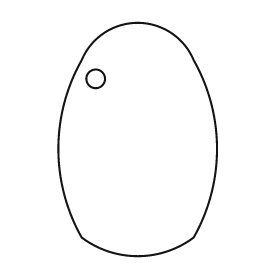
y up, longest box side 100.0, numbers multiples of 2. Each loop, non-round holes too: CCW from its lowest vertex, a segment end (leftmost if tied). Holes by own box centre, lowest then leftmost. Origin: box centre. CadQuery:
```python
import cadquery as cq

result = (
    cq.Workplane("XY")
    .moveTo(-24.0, -42.0)
    .threePointArc((0.0, -50.0), (24.0, -42.0))
    .threePointArc((34.0, -4.0), (24.0, 34.0))
    .threePointArc((0.0, 50.0), (-24.0, 34.0))
    .threePointArc((-34.0, -4.0), (-24.0, -42.0))
    .close()
    .moveTo(-18.0, 26.0)
    .circle(4.0)
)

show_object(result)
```